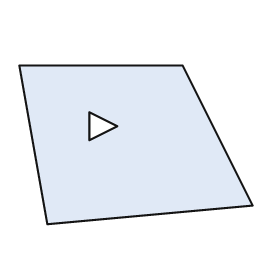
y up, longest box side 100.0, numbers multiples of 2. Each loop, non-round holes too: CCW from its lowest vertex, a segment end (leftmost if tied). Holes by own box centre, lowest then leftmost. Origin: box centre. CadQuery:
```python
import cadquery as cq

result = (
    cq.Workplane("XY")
    .moveTo(-38.0, -34.0)
    .lineTo(50.0, -26.0)
    .lineTo(20.0, 34.0)
    .lineTo(-50.0, 34.0)
    .close()
    .moveTo(-20.0, 2.0)
    .lineTo(-8.0, 8.0)
    .lineTo(-20.0, 14.0)
    .close()
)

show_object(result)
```